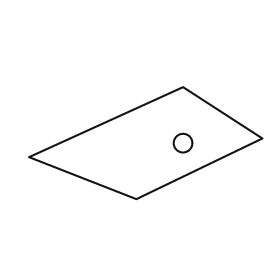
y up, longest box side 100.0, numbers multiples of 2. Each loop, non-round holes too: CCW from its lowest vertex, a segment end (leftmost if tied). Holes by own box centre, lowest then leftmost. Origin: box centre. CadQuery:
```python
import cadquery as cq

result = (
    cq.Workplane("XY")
    .moveTo(-4.0, -24.0)
    .lineTo(50.0, 2.0)
    .lineTo(16.0, 24.0)
    .lineTo(-50.0, -6.0)
    .close()
    .moveTo(16.0, 0.0)
    .circle(4.0)
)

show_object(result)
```